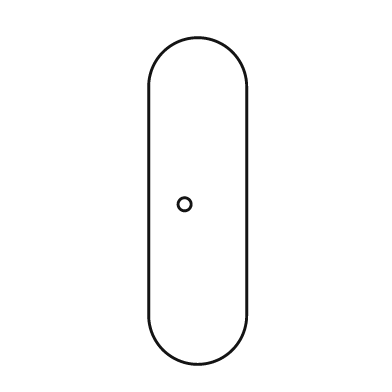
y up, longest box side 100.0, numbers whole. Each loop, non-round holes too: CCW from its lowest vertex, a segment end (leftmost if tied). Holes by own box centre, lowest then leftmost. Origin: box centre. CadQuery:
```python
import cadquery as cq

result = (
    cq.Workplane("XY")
    .moveTo(-15.0, -35.0)
    .threePointArc((0.0, -50.0), (15.0, -35.0))
    .lineTo(15.0, 35.0)
    .threePointArc((0.0, 50.0), (-15.0, 35.0))
    .close()
    .moveTo(-4.0, -1.0)
    .circle(2.0)
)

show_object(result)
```